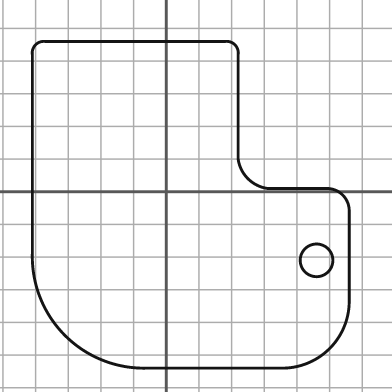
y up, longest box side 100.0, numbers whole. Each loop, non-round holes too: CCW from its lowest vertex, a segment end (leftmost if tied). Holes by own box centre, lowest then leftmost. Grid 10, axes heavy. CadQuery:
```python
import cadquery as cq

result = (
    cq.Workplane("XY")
    .moveTo(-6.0, -54.0)
    .lineTo(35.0, -54.0)
    .threePointArc((50.0, -48.0), (56.0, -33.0))
    .lineTo(56.0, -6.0)
    .threePointArc((54.0, -1.0), (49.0, 1.0))
    .lineTo(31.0, 1.0)
    .threePointArc((25.0, 4.0), (22.0, 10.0))
    .lineTo(22.0, 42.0)
    .threePointArc((21.0, 45.0), (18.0, 46.0))
    .lineTo(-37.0, 46.0)
    .threePointArc((-40.0, 45.0), (-41.0, 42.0))
    .lineTo(-41.0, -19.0)
    .threePointArc((-31.0, -44.0), (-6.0, -54.0))
    .close()
    .moveTo(46.0, -21.0)
    .circle(5.0)
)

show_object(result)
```